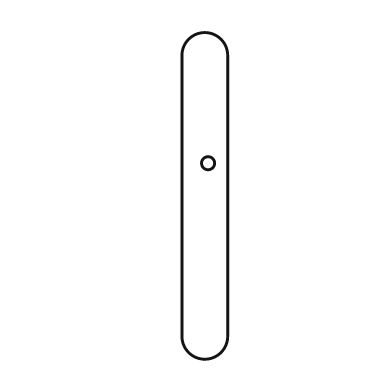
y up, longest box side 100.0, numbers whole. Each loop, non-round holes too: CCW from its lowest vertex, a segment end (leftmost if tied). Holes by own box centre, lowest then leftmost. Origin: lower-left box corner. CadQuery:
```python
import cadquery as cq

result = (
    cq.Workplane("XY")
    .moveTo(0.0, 7.0)
    .threePointArc((7.0, 0.0), (14.0, 7.0))
    .lineTo(14.0, 93.0)
    .threePointArc((7.0, 100.0), (0.0, 93.0))
    .close()
    .moveTo(8.0, 60.0)
    .circle(2.0)
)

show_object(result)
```